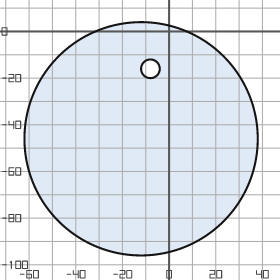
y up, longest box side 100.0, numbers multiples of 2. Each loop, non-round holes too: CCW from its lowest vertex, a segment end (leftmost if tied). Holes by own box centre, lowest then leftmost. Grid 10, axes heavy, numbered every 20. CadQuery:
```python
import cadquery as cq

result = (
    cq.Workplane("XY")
    .moveTo(-12.0, -46.0)
    .circle(50.0)
    .moveTo(-8.0, -16.0)
    .circle(4.0)
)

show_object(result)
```